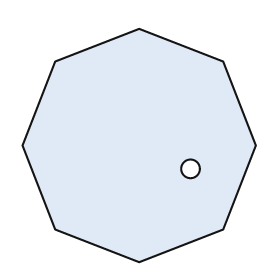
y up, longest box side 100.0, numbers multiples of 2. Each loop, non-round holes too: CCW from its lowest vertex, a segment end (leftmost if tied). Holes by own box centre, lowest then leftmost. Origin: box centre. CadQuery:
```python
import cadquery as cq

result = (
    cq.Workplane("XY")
    .moveTo(0.0, -50.0)
    .lineTo(36.0, -36.0)
    .lineTo(50.0, 0.0)
    .lineTo(36.0, 36.0)
    .lineTo(0.0, 50.0)
    .lineTo(-36.0, 36.0)
    .lineTo(-50.0, 0.0)
    .lineTo(-36.0, -36.0)
    .close()
    .moveTo(22.0, -10.0)
    .circle(4.0)
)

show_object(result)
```